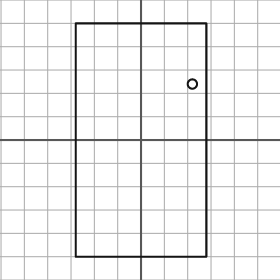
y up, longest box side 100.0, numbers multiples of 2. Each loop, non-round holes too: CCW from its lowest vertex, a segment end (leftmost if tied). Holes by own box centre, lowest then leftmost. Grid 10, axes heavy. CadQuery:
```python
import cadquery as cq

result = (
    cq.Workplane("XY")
    .moveTo(-28.0, -50.0)
    .lineTo(28.0, -50.0)
    .lineTo(28.0, 50.0)
    .lineTo(-28.0, 50.0)
    .close()
    .moveTo(22.0, 24.0)
    .circle(2.0)
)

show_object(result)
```